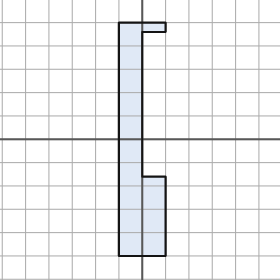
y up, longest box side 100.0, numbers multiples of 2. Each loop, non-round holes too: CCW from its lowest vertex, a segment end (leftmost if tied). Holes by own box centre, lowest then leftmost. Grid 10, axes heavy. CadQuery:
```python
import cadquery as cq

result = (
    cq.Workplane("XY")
    .moveTo(-10.0, -50.0)
    .lineTo(10.0, -50.0)
    .lineTo(10.0, -16.0)
    .lineTo(0.0, -16.0)
    .lineTo(0.0, 46.0)
    .lineTo(10.0, 46.0)
    .lineTo(10.0, 50.0)
    .lineTo(-10.0, 50.0)
    .close()
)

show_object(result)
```